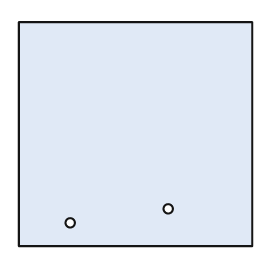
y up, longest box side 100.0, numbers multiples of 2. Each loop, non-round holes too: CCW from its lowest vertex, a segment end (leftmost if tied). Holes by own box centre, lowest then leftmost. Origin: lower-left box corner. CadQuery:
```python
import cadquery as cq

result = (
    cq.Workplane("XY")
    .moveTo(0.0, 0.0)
    .lineTo(100.0, 0.0)
    .lineTo(100.0, 96.0)
    .lineTo(0.0, 96.0)
    .close()
    .moveTo(22.0, 10.0)
    .circle(2.0)
    .moveTo(64.0, 16.0)
    .circle(2.0)
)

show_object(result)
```